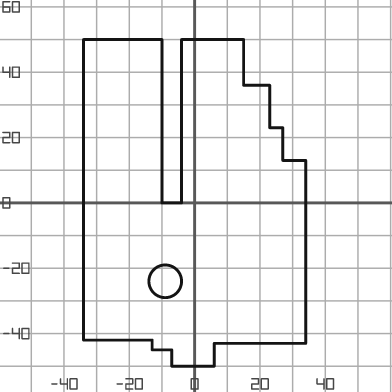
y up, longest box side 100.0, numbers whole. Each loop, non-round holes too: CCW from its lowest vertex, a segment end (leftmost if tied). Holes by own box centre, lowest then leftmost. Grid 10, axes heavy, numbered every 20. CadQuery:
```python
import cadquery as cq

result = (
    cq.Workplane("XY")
    .moveTo(-7.0, -50.0)
    .lineTo(6.0, -50.0)
    .lineTo(6.0, -43.0)
    .lineTo(34.0, -43.0)
    .lineTo(34.0, 13.0)
    .lineTo(27.0, 13.0)
    .lineTo(27.0, 23.0)
    .lineTo(23.0, 23.0)
    .lineTo(23.0, 36.0)
    .lineTo(15.0, 36.0)
    .lineTo(15.0, 50.0)
    .lineTo(-4.0, 50.0)
    .lineTo(-4.0, 0.0)
    .lineTo(-10.0, 0.0)
    .lineTo(-10.0, 50.0)
    .lineTo(-34.0, 50.0)
    .lineTo(-34.0, -42.0)
    .lineTo(-13.0, -42.0)
    .lineTo(-13.0, -45.0)
    .lineTo(-7.0, -45.0)
    .close()
    .moveTo(-9.0, -24.0)
    .circle(5.0)
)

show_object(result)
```